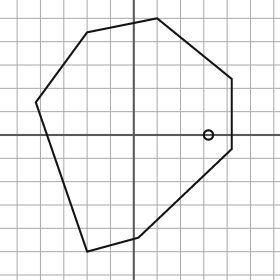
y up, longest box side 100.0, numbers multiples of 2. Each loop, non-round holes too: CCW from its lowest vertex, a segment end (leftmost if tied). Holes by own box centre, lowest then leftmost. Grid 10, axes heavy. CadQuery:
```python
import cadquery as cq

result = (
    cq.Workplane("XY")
    .moveTo(-20.0, -50.0)
    .lineTo(2.0, -44.0)
    .lineTo(42.0, -6.0)
    .lineTo(42.0, 24.0)
    .lineTo(10.0, 50.0)
    .lineTo(-20.0, 44.0)
    .lineTo(-42.0, 14.0)
    .close()
    .moveTo(32.0, 0.0)
    .circle(2.0)
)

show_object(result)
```